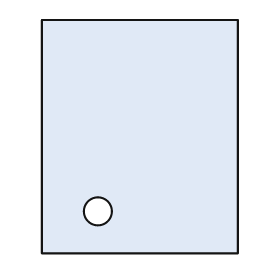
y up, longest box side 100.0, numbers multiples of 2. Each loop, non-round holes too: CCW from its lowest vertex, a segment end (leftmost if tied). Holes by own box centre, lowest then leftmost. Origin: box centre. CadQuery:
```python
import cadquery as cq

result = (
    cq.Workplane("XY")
    .moveTo(-42.0, -50.0)
    .lineTo(42.0, -50.0)
    .lineTo(42.0, 50.0)
    .lineTo(-42.0, 50.0)
    .close()
    .moveTo(-18.0, -32.0)
    .circle(6.0)
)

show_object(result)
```